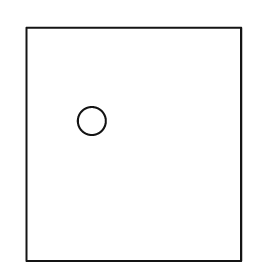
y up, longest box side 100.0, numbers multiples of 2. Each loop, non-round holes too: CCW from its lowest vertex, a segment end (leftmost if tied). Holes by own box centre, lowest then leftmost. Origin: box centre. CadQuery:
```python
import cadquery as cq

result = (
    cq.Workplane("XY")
    .moveTo(-46.0, -50.0)
    .lineTo(46.0, -50.0)
    .lineTo(46.0, 50.0)
    .lineTo(-46.0, 50.0)
    .close()
    .moveTo(-18.0, 10.0)
    .circle(6.0)
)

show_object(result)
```